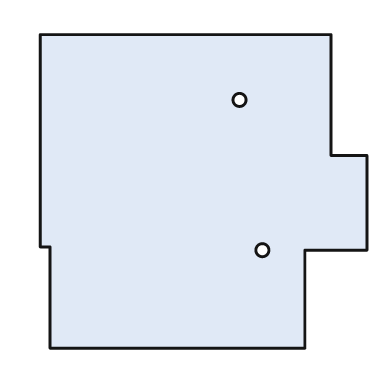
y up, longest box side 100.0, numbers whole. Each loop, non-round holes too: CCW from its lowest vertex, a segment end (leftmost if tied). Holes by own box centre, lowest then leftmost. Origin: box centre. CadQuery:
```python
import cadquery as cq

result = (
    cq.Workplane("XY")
    .moveTo(-47.0, -48.0)
    .lineTo(31.0, -48.0)
    .lineTo(31.0, -18.0)
    .lineTo(50.0, -18.0)
    .lineTo(50.0, 11.0)
    .lineTo(39.0, 11.0)
    .lineTo(39.0, 48.0)
    .lineTo(-50.0, 48.0)
    .lineTo(-50.0, -17.0)
    .lineTo(-47.0, -17.0)
    .close()
    .moveTo(18.0, -18.0)
    .circle(2.0)
    .moveTo(11.0, 28.0)
    .circle(2.0)
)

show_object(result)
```